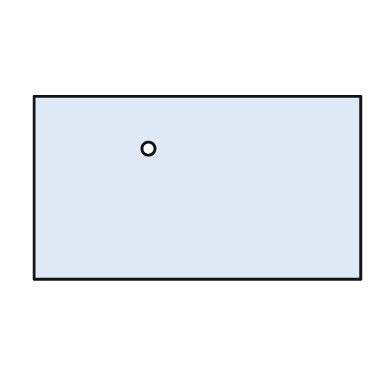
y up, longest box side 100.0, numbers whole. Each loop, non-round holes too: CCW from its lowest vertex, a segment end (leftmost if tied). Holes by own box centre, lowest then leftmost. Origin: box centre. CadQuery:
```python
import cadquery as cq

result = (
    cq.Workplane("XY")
    .moveTo(-50.0, -28.0)
    .lineTo(50.0, -28.0)
    .lineTo(50.0, 28.0)
    .lineTo(-50.0, 28.0)
    .close()
    .moveTo(-15.0, 12.0)
    .circle(2.0)
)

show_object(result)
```